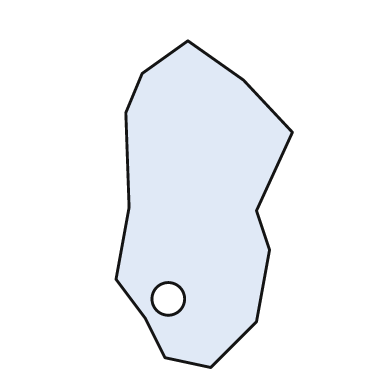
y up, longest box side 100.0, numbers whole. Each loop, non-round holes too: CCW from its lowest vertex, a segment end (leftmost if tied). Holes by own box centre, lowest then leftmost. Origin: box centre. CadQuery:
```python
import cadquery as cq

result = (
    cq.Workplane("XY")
    .moveTo(2.0, -50.0)
    .lineTo(16.0, -36.0)
    .lineTo(20.0, -14.0)
    .lineTo(16.0, -2.0)
    .lineTo(27.0, 22.0)
    .lineTo(12.0, 38.0)
    .lineTo(-5.0, 50.0)
    .lineTo(-19.0, 40.0)
    .lineTo(-24.0, 28.0)
    .lineTo(-23.0, -1.0)
    .lineTo(-27.0, -23.0)
    .lineTo(-18.0, -35.0)
    .lineTo(-12.0, -47.0)
    .close()
    .moveTo(-11.0, -29.0)
    .circle(5.0)
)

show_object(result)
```